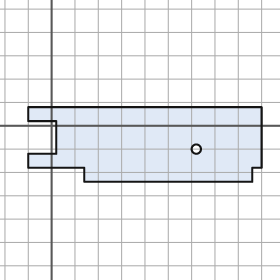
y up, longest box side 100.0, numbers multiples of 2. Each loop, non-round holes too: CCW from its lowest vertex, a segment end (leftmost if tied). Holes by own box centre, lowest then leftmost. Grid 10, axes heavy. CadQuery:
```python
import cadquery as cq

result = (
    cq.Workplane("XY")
    .moveTo(14.0, -24.0)
    .lineTo(86.0, -24.0)
    .lineTo(86.0, -18.0)
    .lineTo(90.0, -18.0)
    .lineTo(90.0, 8.0)
    .lineTo(-10.0, 8.0)
    .lineTo(-10.0, 2.0)
    .lineTo(2.0, 2.0)
    .lineTo(2.0, -12.0)
    .lineTo(-10.0, -12.0)
    .lineTo(-10.0, -18.0)
    .lineTo(14.0, -18.0)
    .close()
    .moveTo(62.0, -10.0)
    .circle(2.0)
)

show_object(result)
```